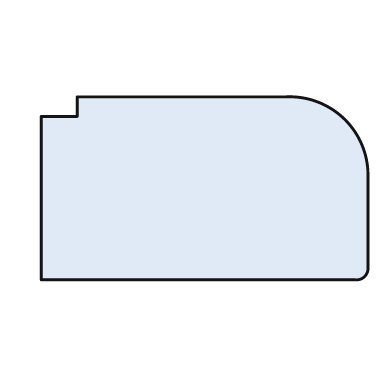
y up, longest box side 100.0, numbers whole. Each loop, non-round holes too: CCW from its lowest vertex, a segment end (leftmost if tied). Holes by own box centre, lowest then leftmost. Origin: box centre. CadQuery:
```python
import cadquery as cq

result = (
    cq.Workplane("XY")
    .moveTo(-50.0, -28.0)
    .lineTo(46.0, -28.0)
    .threePointArc((49.0, -27.0), (50.0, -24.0))
    .lineTo(50.0, 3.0)
    .threePointArc((43.0, 21.0), (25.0, 28.0))
    .lineTo(-39.0, 28.0)
    .lineTo(-39.0, 22.0)
    .lineTo(-50.0, 22.0)
    .close()
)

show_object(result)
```